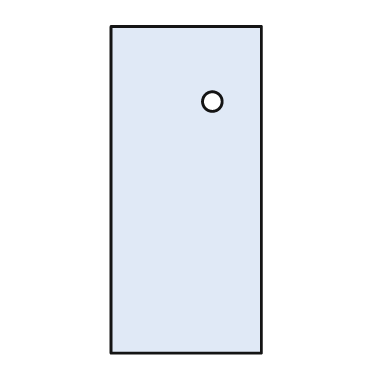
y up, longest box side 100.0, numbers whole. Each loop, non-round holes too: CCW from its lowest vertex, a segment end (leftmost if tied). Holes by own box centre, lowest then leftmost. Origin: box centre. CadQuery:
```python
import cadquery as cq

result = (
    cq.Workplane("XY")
    .moveTo(-23.0, -50.0)
    .lineTo(23.0, -50.0)
    .lineTo(23.0, 50.0)
    .lineTo(-23.0, 50.0)
    .close()
    .moveTo(8.0, 27.0)
    .circle(3.0)
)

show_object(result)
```